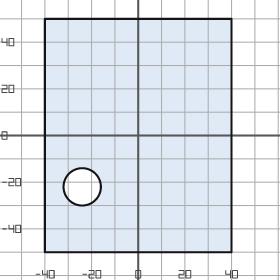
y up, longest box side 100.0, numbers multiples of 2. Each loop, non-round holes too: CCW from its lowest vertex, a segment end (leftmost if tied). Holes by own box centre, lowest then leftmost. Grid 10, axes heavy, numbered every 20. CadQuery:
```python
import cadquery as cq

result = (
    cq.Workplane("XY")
    .moveTo(-40.0, -50.0)
    .lineTo(40.0, -50.0)
    .lineTo(40.0, 50.0)
    .lineTo(-40.0, 50.0)
    .close()
    .moveTo(-24.0, -22.0)
    .circle(8.0)
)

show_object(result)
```